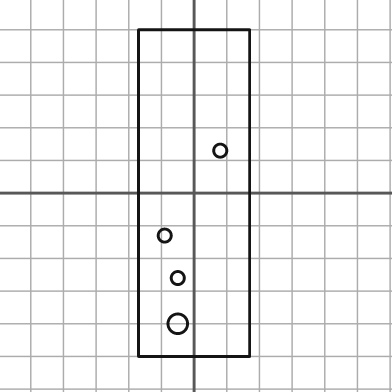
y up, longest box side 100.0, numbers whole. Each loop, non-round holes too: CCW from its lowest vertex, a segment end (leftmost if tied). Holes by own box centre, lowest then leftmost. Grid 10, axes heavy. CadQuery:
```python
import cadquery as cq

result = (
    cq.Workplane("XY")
    .moveTo(-17.0, -50.0)
    .lineTo(17.0, -50.0)
    .lineTo(17.0, 50.0)
    .lineTo(-17.0, 50.0)
    .close()
    .moveTo(-5.0, -40.0)
    .circle(3.0)
    .moveTo(-5.0, -26.0)
    .circle(2.0)
    .moveTo(-9.0, -13.0)
    .circle(2.0)
    .moveTo(8.0, 13.0)
    .circle(2.0)
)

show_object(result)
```